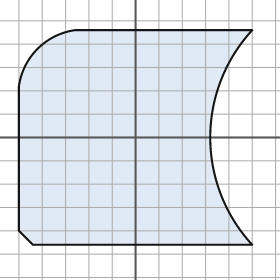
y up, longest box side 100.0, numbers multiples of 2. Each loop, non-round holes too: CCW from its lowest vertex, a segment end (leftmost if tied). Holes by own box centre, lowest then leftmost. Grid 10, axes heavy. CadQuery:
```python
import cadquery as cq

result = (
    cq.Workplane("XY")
    .moveTo(-44.0, -46.0)
    .lineTo(50.0, -46.0)
    .threePointArc((32.0, 0.0), (50.0, 46.0))
    .lineTo(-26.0, 46.0)
    .threePointArc((-42.0, 38.0), (-50.0, 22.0))
    .lineTo(-50.0, -40.0)
    .close()
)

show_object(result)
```